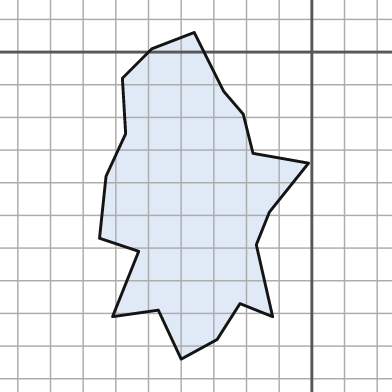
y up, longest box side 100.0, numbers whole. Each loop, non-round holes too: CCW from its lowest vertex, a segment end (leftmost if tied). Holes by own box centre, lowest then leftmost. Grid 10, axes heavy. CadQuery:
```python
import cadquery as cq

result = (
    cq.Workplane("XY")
    .moveTo(-40.0, -94.0)
    .lineTo(-29.0, -88.0)
    .lineTo(-22.0, -77.0)
    .lineTo(-12.0, -81.0)
    .lineTo(-17.0, -59.0)
    .lineTo(-13.0, -49.0)
    .lineTo(-1.0, -34.0)
    .lineTo(-18.0, -31.0)
    .lineTo(-21.0, -19.0)
    .lineTo(-27.0, -12.0)
    .lineTo(-36.0, 6.0)
    .lineTo(-49.0, 1.0)
    .lineTo(-58.0, -8.0)
    .lineTo(-57.0, -25.0)
    .lineTo(-63.0, -38.0)
    .lineTo(-65.0, -57.0)
    .lineTo(-53.0, -61.0)
    .lineTo(-61.0, -81.0)
    .lineTo(-47.0, -79.0)
    .close()
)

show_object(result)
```